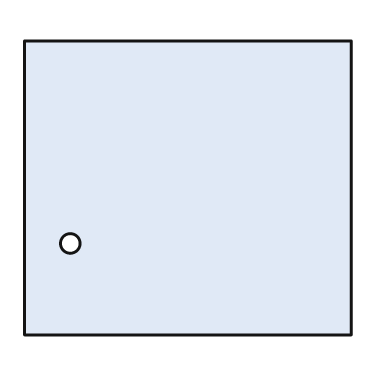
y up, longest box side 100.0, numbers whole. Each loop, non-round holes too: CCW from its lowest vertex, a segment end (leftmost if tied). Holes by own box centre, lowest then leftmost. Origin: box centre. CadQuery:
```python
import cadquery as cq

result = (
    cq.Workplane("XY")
    .moveTo(-50.0, -45.0)
    .lineTo(50.0, -45.0)
    .lineTo(50.0, 45.0)
    .lineTo(-50.0, 45.0)
    .close()
    .moveTo(-36.0, -17.0)
    .circle(3.0)
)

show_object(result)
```